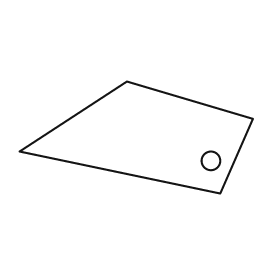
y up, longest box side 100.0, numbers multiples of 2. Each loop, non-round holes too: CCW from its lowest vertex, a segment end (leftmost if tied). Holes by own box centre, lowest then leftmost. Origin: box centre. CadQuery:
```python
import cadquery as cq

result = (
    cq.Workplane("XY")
    .moveTo(36.0, -24.0)
    .lineTo(50.0, 8.0)
    .lineTo(-4.0, 24.0)
    .lineTo(-50.0, -6.0)
    .close()
    .moveTo(32.0, -10.0)
    .circle(4.0)
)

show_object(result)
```